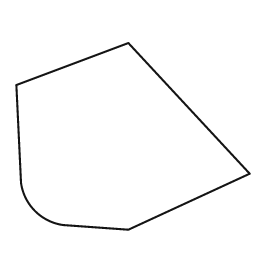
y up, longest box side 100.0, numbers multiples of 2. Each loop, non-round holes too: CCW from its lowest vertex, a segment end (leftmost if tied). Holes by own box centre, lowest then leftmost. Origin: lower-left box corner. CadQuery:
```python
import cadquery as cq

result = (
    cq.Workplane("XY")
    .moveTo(48.0, 0.0)
    .lineTo(100.0, 24.0)
    .lineTo(48.0, 80.0)
    .lineTo(0.0, 62.0)
    .lineTo(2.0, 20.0)
    .threePointArc((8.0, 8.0), (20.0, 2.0))
    .close()
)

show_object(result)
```